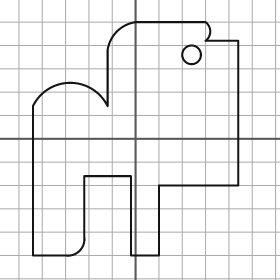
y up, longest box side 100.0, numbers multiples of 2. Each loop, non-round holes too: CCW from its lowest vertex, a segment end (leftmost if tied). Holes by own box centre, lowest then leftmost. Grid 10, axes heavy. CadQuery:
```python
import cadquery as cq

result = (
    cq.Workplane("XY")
    .moveTo(-44.0, -50.0)
    .lineTo(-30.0, -50.0)
    .threePointArc((-24.0, -48.0), (-22.0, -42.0))
    .lineTo(-22.0, -16.0)
    .lineTo(-2.0, -16.0)
    .lineTo(-2.0, -50.0)
    .lineTo(10.0, -50.0)
    .lineTo(10.0, -20.0)
    .lineTo(44.0, -20.0)
    .lineTo(44.0, 42.0)
    .lineTo(30.0, 42.0)
    .threePointArc((32.0, 46.0), (30.0, 50.0))
    .lineTo(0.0, 50.0)
    .threePointArc((-8.0, 46.0), (-12.0, 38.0))
    .lineTo(-12.0, 14.0)
    .threePointArc((-28.0, 24.0), (-44.0, 14.0))
    .close()
    .moveTo(24.0, 36.0)
    .circle(4.0)
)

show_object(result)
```